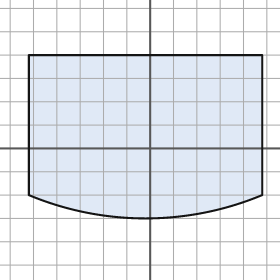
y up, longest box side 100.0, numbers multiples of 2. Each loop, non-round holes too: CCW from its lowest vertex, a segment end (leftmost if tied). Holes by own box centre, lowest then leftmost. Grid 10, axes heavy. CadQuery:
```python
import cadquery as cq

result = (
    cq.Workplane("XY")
    .moveTo(-52.0, -20.0)
    .threePointArc((-2.0, -30.0), (48.0, -20.0))
    .lineTo(48.0, 40.0)
    .lineTo(-52.0, 40.0)
    .close()
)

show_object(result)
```